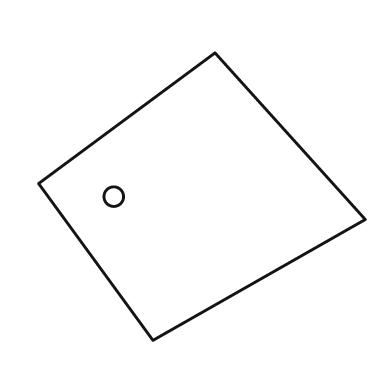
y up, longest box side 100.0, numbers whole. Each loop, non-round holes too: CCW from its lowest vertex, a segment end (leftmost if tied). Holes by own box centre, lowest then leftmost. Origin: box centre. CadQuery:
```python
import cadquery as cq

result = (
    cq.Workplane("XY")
    .moveTo(-15.0, -44.0)
    .lineTo(50.0, -7.0)
    .lineTo(4.0, 44.0)
    .lineTo(-50.0, 4.0)
    .close()
    .moveTo(-27.0, 0.0)
    .circle(3.0)
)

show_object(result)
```